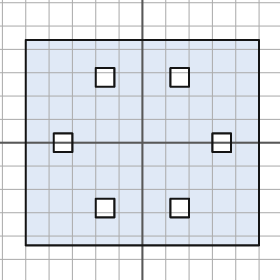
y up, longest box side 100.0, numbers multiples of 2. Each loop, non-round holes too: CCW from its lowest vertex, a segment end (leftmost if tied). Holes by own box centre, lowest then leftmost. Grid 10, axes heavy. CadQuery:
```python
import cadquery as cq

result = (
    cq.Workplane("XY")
    .moveTo(-50.0, -44.0)
    .lineTo(50.0, -44.0)
    .lineTo(50.0, 44.0)
    .lineTo(-50.0, 44.0)
    .close()
    .moveTo(-20.0, -32.0)
    .lineTo(-12.0, -32.0)
    .lineTo(-12.0, -24.0)
    .lineTo(-20.0, -24.0)
    .close()
    .moveTo(12.0, -32.0)
    .lineTo(20.0, -32.0)
    .lineTo(20.0, -24.0)
    .lineTo(12.0, -24.0)
    .close()
    .moveTo(-38.0, -4.0)
    .lineTo(-30.0, -4.0)
    .lineTo(-30.0, 4.0)
    .lineTo(-38.0, 4.0)
    .close()
    .moveTo(30.0, -4.0)
    .lineTo(38.0, -4.0)
    .lineTo(38.0, 4.0)
    .lineTo(30.0, 4.0)
    .close()
    .moveTo(-20.0, 24.0)
    .lineTo(-12.0, 24.0)
    .lineTo(-12.0, 32.0)
    .lineTo(-20.0, 32.0)
    .close()
    .moveTo(12.0, 24.0)
    .lineTo(20.0, 24.0)
    .lineTo(20.0, 32.0)
    .lineTo(12.0, 32.0)
    .close()
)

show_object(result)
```